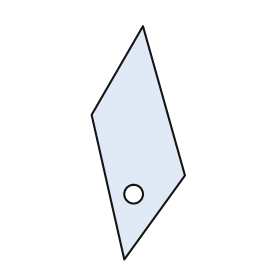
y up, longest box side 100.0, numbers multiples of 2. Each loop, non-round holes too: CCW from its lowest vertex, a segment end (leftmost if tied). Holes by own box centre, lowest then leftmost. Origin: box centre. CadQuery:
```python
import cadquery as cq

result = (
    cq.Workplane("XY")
    .moveTo(-6.0, -50.0)
    .lineTo(20.0, -14.0)
    .lineTo(2.0, 50.0)
    .lineTo(-20.0, 12.0)
    .close()
    .moveTo(-2.0, -22.0)
    .circle(4.0)
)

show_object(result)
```